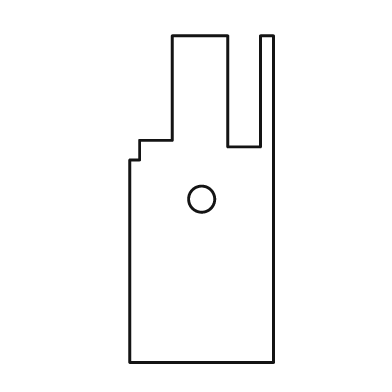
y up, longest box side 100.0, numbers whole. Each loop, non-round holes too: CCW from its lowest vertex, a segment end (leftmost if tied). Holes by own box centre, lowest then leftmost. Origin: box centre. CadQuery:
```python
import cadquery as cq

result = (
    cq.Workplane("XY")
    .moveTo(-22.0, -50.0)
    .lineTo(22.0, -50.0)
    .lineTo(22.0, 50.0)
    .lineTo(18.0, 50.0)
    .lineTo(18.0, 16.0)
    .lineTo(8.0, 16.0)
    .lineTo(8.0, 50.0)
    .lineTo(-9.0, 50.0)
    .lineTo(-9.0, 18.0)
    .lineTo(-19.0, 18.0)
    .lineTo(-19.0, 12.0)
    .lineTo(-22.0, 12.0)
    .close()
    .moveTo(0.0, 0.0)
    .circle(4.0)
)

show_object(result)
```